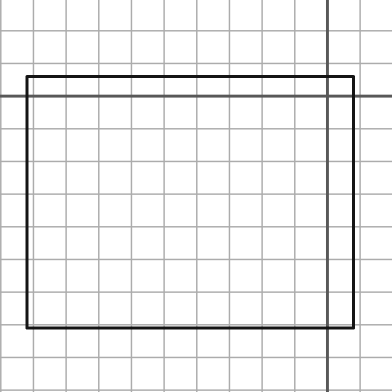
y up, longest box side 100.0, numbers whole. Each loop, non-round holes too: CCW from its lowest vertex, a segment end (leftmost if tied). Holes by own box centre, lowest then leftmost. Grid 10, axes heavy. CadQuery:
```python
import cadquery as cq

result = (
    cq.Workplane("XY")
    .moveTo(-92.0, -71.0)
    .lineTo(8.0, -71.0)
    .lineTo(8.0, 6.0)
    .lineTo(-92.0, 6.0)
    .close()
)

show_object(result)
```